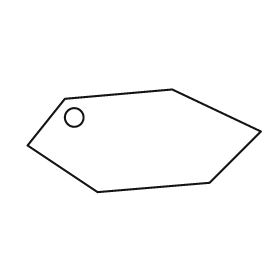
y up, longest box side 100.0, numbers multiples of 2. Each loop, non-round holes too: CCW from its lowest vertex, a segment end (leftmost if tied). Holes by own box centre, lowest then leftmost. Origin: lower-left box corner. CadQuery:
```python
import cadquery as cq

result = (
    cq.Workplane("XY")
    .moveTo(30.0, 0.0)
    .lineTo(78.0, 4.0)
    .lineTo(100.0, 26.0)
    .lineTo(62.0, 44.0)
    .lineTo(16.0, 40.0)
    .lineTo(0.0, 20.0)
    .close()
    .moveTo(20.0, 32.0)
    .circle(4.0)
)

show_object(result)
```